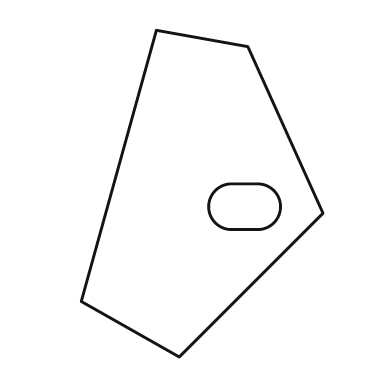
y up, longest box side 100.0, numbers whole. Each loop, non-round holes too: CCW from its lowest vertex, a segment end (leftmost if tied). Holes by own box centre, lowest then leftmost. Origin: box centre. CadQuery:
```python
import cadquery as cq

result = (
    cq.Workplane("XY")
    .moveTo(-7.0, -50.0)
    .lineTo(37.0, -6.0)
    .lineTo(14.0, 45.0)
    .lineTo(-14.0, 50.0)
    .lineTo(-37.0, -33.0)
    .close()
    .moveTo(9.0, -11.0)
    .lineTo(17.0, -11.0)
    .threePointArc((24.0, -4.0), (17.0, 3.0))
    .lineTo(9.0, 3.0)
    .threePointArc((2.0, -4.0), (9.0, -11.0))
    .close()
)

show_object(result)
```